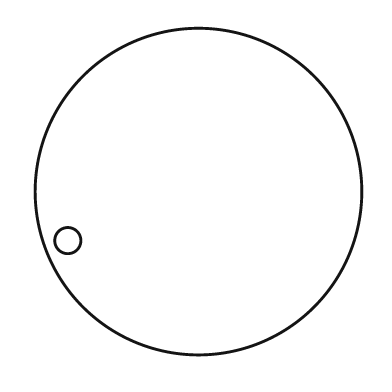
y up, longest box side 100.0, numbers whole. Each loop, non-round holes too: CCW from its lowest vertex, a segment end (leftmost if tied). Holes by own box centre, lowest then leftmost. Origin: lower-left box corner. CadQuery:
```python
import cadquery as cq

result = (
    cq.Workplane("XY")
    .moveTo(50.0, 50.0)
    .circle(50.0)
    .moveTo(10.0, 35.0)
    .circle(4.0)
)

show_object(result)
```